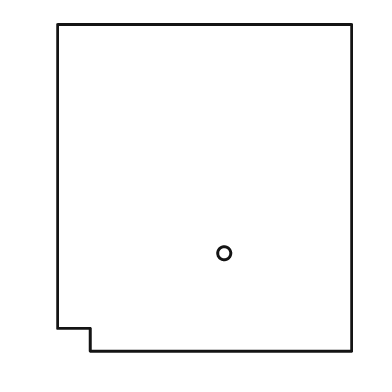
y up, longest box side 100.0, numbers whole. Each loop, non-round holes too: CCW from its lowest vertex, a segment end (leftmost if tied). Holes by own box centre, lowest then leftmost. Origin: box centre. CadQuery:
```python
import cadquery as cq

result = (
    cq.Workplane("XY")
    .moveTo(-35.0, -50.0)
    .lineTo(45.0, -50.0)
    .lineTo(45.0, 50.0)
    .lineTo(-45.0, 50.0)
    .lineTo(-45.0, -43.0)
    .lineTo(-35.0, -43.0)
    .close()
    .moveTo(6.0, -20.0)
    .circle(2.0)
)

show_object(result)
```